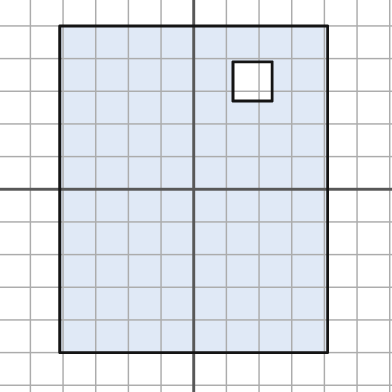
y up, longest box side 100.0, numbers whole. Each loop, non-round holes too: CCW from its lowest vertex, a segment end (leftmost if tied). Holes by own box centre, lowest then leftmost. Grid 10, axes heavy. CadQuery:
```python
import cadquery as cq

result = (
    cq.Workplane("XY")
    .moveTo(-41.0, -50.0)
    .lineTo(41.0, -50.0)
    .lineTo(41.0, 50.0)
    .lineTo(-41.0, 50.0)
    .close()
    .moveTo(12.0, 27.0)
    .lineTo(24.0, 27.0)
    .lineTo(24.0, 39.0)
    .lineTo(12.0, 39.0)
    .close()
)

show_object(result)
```